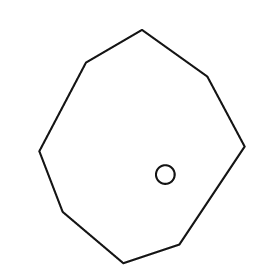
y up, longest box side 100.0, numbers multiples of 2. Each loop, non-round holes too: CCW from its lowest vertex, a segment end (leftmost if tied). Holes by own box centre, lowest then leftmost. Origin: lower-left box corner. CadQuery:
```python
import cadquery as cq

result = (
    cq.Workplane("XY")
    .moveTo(36.0, 0.0)
    .lineTo(60.0, 8.0)
    .lineTo(88.0, 50.0)
    .lineTo(72.0, 80.0)
    .lineTo(44.0, 100.0)
    .lineTo(20.0, 86.0)
    .lineTo(0.0, 48.0)
    .lineTo(10.0, 22.0)
    .close()
    .moveTo(54.0, 38.0)
    .circle(4.0)
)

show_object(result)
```